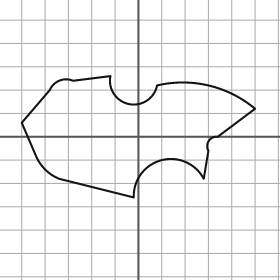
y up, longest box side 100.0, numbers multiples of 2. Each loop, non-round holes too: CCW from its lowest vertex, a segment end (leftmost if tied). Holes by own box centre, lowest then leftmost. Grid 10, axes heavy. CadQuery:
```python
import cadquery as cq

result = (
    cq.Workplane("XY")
    .moveTo(-2.0, -26.0)
    .threePointArc((10.0, -10.0), (28.0, -18.0))
    .lineTo(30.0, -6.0)
    .threePointArc((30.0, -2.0), (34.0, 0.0))
    .lineTo(50.0, 12.0)
    .threePointArc((30.0, 22.0), (8.0, 22.0))
    .threePointArc((-4.0, 14.0), (-12.0, 26.0))
    .lineTo(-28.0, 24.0)
    .threePointArc((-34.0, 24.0), (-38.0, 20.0))
    .lineTo(-50.0, 6.0)
    .lineTo(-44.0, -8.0)
    .threePointArc((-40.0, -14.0), (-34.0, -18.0))
    .close()
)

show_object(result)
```